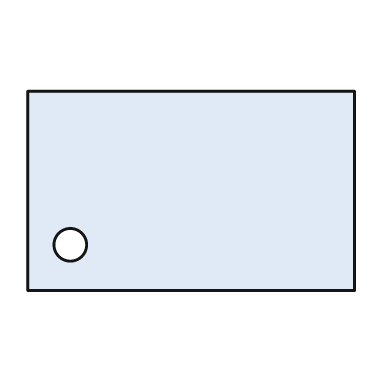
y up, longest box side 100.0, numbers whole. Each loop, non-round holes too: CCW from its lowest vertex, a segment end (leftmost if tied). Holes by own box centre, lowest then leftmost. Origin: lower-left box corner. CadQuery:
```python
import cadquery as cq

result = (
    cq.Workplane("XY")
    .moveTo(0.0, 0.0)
    .lineTo(100.0, 0.0)
    .lineTo(100.0, 61.0)
    .lineTo(0.0, 61.0)
    .close()
    .moveTo(13.0, 14.0)
    .circle(5.0)
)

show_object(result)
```